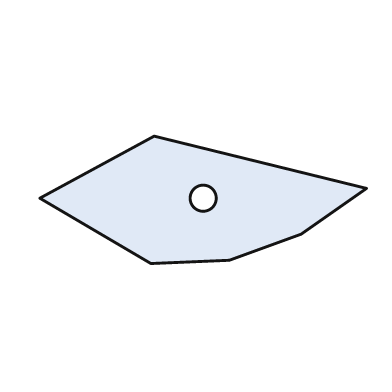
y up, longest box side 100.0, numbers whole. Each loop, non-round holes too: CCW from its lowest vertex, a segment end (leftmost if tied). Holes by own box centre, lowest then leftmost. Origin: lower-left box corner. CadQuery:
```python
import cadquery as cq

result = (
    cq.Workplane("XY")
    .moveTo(34.0, 0.0)
    .lineTo(58.0, 1.0)
    .lineTo(80.0, 9.0)
    .lineTo(100.0, 23.0)
    .lineTo(35.0, 39.0)
    .lineTo(0.0, 20.0)
    .close()
    .moveTo(50.0, 20.0)
    .circle(4.0)
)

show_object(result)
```